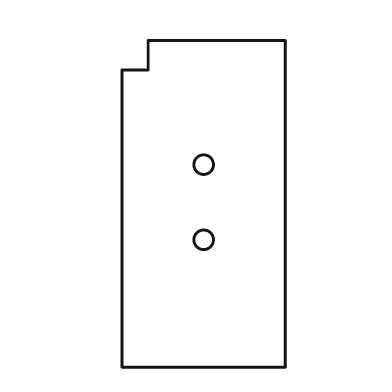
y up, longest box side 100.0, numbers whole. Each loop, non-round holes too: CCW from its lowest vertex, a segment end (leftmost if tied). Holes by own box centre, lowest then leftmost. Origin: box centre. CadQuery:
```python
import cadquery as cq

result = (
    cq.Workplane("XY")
    .moveTo(-25.0, -50.0)
    .lineTo(25.0, -50.0)
    .lineTo(25.0, 50.0)
    .lineTo(-17.0, 50.0)
    .lineTo(-17.0, 41.0)
    .lineTo(-25.0, 41.0)
    .close()
    .moveTo(0.0, -11.0)
    .circle(3.0)
    .moveTo(0.0, 12.0)
    .circle(3.0)
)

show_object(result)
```